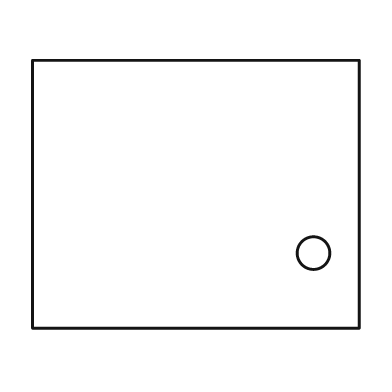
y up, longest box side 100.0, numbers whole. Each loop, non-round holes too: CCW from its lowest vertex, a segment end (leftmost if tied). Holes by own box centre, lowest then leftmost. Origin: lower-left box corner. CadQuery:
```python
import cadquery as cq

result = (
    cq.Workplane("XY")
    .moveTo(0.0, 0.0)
    .lineTo(100.0, 0.0)
    .lineTo(100.0, 82.0)
    .lineTo(0.0, 82.0)
    .close()
    .moveTo(86.0, 23.0)
    .circle(5.0)
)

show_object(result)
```